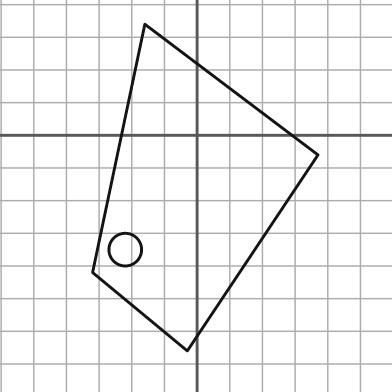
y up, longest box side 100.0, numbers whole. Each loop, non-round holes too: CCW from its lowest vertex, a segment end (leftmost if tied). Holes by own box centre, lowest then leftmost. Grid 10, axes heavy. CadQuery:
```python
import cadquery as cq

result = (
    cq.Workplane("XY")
    .moveTo(-3.0, -66.0)
    .lineTo(37.0, -6.0)
    .lineTo(-16.0, 34.0)
    .lineTo(-32.0, -42.0)
    .close()
    .moveTo(-22.0, -35.0)
    .circle(5.0)
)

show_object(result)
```